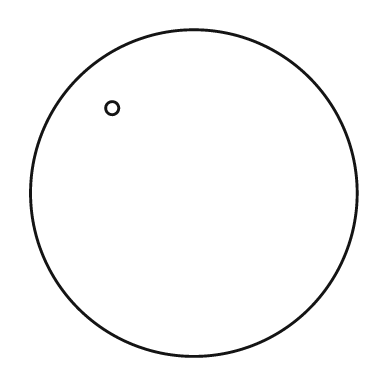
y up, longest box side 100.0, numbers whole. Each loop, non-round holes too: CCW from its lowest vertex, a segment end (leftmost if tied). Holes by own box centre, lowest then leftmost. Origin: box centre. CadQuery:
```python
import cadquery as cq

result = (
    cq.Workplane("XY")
    .moveTo(0.0, 0.0)
    .circle(50.0)
    .moveTo(-25.0, 26.0)
    .circle(2.0)
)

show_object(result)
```